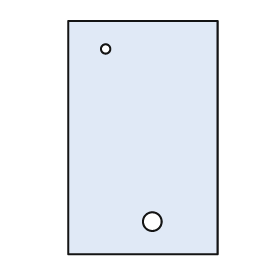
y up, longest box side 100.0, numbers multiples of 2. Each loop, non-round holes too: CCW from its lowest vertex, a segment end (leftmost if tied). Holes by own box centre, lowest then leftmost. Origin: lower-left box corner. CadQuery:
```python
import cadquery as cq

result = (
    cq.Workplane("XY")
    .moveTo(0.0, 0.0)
    .lineTo(64.0, 0.0)
    .lineTo(64.0, 100.0)
    .lineTo(0.0, 100.0)
    .close()
    .moveTo(36.0, 14.0)
    .circle(4.0)
    .moveTo(16.0, 88.0)
    .circle(2.0)
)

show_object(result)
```